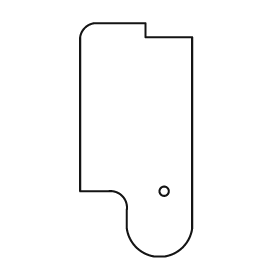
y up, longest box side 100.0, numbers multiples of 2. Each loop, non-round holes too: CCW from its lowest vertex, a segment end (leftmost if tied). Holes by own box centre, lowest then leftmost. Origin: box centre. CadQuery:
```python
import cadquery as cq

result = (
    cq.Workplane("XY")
    .moveTo(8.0, -50.0)
    .lineTo(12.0, -50.0)
    .threePointArc((20.0, -46.0), (24.0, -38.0))
    .lineTo(24.0, 44.0)
    .lineTo(4.0, 44.0)
    .lineTo(4.0, 50.0)
    .lineTo(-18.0, 50.0)
    .threePointArc((-22.0, 48.0), (-24.0, 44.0))
    .lineTo(-24.0, -22.0)
    .lineTo(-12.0, -22.0)
    .threePointArc((-6.0, -24.0), (-4.0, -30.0))
    .lineTo(-4.0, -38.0)
    .threePointArc((0.0, -46.0), (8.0, -50.0))
    .close()
    .moveTo(12.0, -22.0)
    .circle(2.0)
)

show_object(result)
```